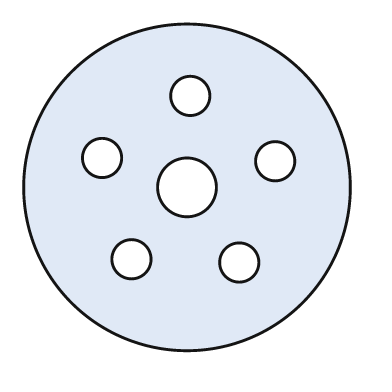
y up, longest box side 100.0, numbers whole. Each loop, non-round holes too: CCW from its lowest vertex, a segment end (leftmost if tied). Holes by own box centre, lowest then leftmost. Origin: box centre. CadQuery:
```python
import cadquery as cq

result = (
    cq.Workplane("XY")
    .moveTo(0.0, 0.0)
    .circle(50.0)
    .moveTo(16.0, -23.0)
    .circle(6.0)
    .moveTo(-17.0, -22.0)
    .circle(6.0)
    .moveTo(0.0, 0.0)
    .circle(9.0)
    .moveTo(27.0, 8.0)
    .circle(6.0)
    .moveTo(-26.0, 9.0)
    .circle(6.0)
    .moveTo(1.0, 28.0)
    .circle(6.0)
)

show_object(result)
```